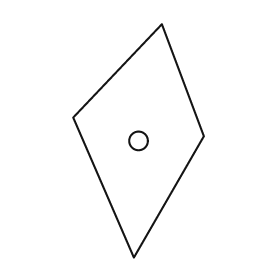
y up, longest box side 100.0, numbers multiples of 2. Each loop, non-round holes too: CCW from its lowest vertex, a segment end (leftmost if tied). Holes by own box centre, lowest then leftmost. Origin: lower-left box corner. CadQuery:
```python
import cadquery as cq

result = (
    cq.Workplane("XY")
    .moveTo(26.0, 0.0)
    .lineTo(56.0, 52.0)
    .lineTo(38.0, 100.0)
    .lineTo(0.0, 60.0)
    .close()
    .moveTo(28.0, 50.0)
    .circle(4.0)
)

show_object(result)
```